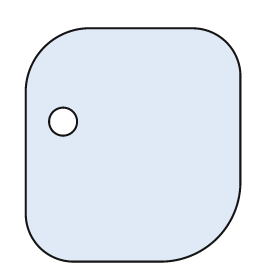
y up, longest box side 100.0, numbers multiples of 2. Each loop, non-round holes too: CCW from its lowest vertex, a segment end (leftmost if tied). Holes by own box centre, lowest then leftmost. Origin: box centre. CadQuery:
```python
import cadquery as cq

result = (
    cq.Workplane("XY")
    .moveTo(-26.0, -50.0)
    .lineTo(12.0, -50.0)
    .threePointArc((36.0, -40.0), (46.0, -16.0))
    .lineTo(46.0, 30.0)
    .threePointArc((40.0, 44.0), (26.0, 50.0))
    .lineTo(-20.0, 50.0)
    .threePointArc((-38.0, 42.0), (-46.0, 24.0))
    .lineTo(-46.0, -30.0)
    .threePointArc((-40.0, -44.0), (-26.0, -50.0))
    .close()
    .moveTo(-30.0, 10.0)
    .circle(6.0)
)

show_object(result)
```